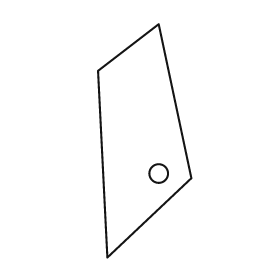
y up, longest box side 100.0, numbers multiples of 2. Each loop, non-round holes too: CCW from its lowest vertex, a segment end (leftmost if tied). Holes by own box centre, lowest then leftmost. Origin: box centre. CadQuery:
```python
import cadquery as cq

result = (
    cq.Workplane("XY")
    .moveTo(-16.0, -50.0)
    .lineTo(20.0, -16.0)
    .lineTo(6.0, 50.0)
    .lineTo(-20.0, 30.0)
    .close()
    .moveTo(6.0, -14.0)
    .circle(4.0)
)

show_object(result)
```